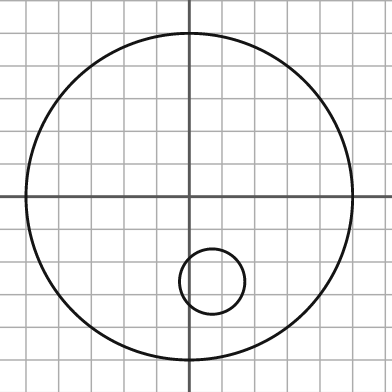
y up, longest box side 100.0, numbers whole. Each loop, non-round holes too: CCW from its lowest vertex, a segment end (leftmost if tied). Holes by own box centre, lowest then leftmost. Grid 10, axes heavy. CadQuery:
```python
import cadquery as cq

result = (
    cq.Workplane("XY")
    .moveTo(0.0, 0.0)
    .circle(50.0)
    .moveTo(7.0, -26.0)
    .circle(10.0)
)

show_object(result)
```